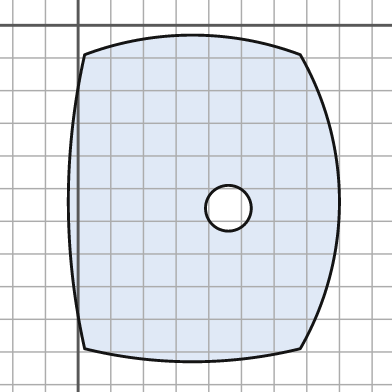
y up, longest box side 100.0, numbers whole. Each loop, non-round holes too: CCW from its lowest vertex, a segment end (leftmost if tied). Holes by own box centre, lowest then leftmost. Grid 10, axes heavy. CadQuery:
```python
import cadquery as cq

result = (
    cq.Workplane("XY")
    .moveTo(2.0, -99.0)
    .threePointArc((35.0, -103.0), (68.0, -99.0))
    .threePointArc((80.0, -54.0), (68.0, -9.0))
    .threePointArc((35.0, -3.0), (2.0, -9.0))
    .threePointArc((-3.0, -54.0), (2.0, -99.0))
    .close()
    .moveTo(46.0, -56.0)
    .circle(7.0)
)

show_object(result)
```